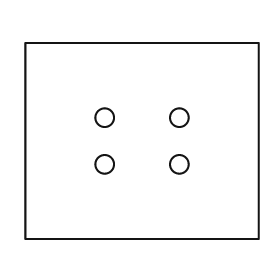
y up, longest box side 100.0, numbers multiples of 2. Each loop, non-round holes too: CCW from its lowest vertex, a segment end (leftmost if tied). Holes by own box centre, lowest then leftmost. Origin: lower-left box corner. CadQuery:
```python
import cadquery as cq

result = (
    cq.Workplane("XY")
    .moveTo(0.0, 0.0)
    .lineTo(100.0, 0.0)
    .lineTo(100.0, 84.0)
    .lineTo(0.0, 84.0)
    .close()
    .moveTo(34.0, 32.0)
    .circle(4.0)
    .moveTo(66.0, 32.0)
    .circle(4.0)
    .moveTo(34.0, 52.0)
    .circle(4.0)
    .moveTo(66.0, 52.0)
    .circle(4.0)
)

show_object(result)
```